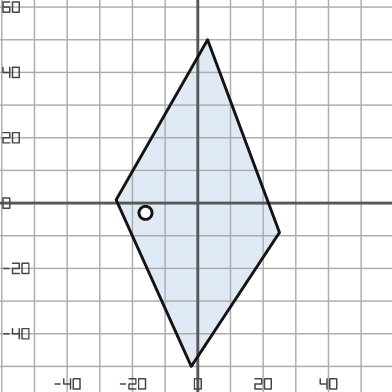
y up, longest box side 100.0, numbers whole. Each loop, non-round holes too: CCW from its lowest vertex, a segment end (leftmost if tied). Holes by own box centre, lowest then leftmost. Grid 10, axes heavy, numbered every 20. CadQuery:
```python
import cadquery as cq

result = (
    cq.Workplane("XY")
    .moveTo(-2.0, -50.0)
    .lineTo(25.0, -9.0)
    .lineTo(3.0, 50.0)
    .lineTo(-25.0, 1.0)
    .close()
    .moveTo(-16.0, -3.0)
    .circle(2.0)
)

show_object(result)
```